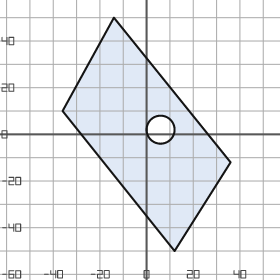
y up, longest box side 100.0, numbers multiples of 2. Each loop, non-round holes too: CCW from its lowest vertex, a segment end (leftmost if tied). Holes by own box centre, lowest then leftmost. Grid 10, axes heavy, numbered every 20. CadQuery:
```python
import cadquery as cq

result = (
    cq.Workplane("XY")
    .moveTo(12.0, -50.0)
    .lineTo(36.0, -12.0)
    .lineTo(-14.0, 50.0)
    .lineTo(-36.0, 10.0)
    .close()
    .moveTo(6.0, 2.0)
    .circle(6.0)
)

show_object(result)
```